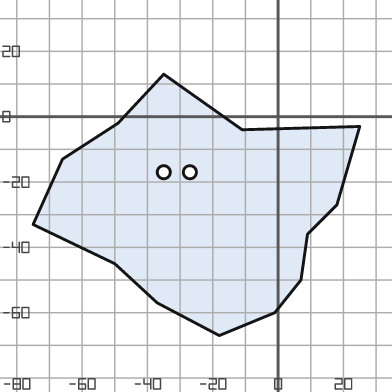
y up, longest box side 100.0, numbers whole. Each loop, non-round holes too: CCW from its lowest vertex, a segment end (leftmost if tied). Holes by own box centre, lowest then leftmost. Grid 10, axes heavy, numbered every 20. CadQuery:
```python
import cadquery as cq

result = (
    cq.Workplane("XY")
    .moveTo(-18.0, -67.0)
    .lineTo(-1.0, -60.0)
    .lineTo(7.0, -50.0)
    .lineTo(9.0, -36.0)
    .lineTo(18.0, -27.0)
    .lineTo(25.0, -3.0)
    .lineTo(-11.0, -4.0)
    .lineTo(-35.0, 13.0)
    .lineTo(-49.0, -2.0)
    .lineTo(-66.0, -13.0)
    .lineTo(-75.0, -33.0)
    .lineTo(-50.0, -45.0)
    .lineTo(-37.0, -57.0)
    .close()
    .moveTo(-35.0, -17.0)
    .circle(2.0)
    .moveTo(-27.0, -17.0)
    .circle(2.0)
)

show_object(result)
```